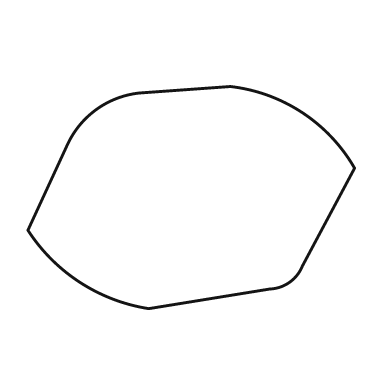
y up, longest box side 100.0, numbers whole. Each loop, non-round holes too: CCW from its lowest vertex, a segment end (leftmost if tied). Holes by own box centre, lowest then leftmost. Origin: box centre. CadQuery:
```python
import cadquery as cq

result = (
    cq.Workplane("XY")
    .moveTo(-13.0, -34.0)
    .lineTo(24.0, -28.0)
    .threePointArc((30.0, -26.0), (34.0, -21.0))
    .lineTo(50.0, 9.0)
    .threePointArc((34.0, 26.0), (12.0, 34.0))
    .lineTo(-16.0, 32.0)
    .threePointArc((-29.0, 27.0), (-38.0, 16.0))
    .lineTo(-50.0, -10.0)
    .threePointArc((-34.0, -26.0), (-13.0, -34.0))
    .close()
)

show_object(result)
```